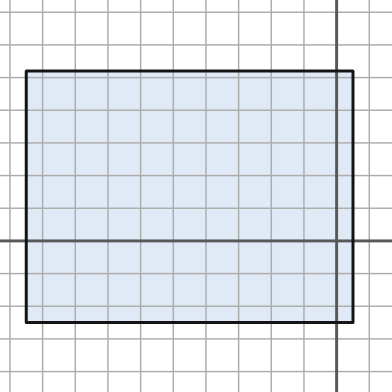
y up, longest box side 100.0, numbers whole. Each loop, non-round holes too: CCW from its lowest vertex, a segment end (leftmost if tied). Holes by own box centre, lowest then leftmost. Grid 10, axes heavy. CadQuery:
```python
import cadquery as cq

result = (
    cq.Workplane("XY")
    .moveTo(-95.0, -25.0)
    .lineTo(5.0, -25.0)
    .lineTo(5.0, 52.0)
    .lineTo(-95.0, 52.0)
    .close()
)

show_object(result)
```